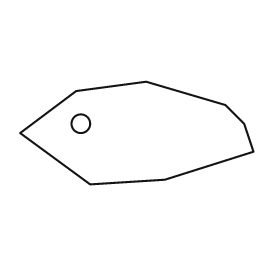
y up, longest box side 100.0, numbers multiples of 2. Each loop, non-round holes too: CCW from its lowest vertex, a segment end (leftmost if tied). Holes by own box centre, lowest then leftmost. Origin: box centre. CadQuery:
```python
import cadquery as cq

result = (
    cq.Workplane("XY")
    .moveTo(-20.0, -22.0)
    .lineTo(12.0, -20.0)
    .lineTo(50.0, -8.0)
    .lineTo(46.0, 4.0)
    .lineTo(38.0, 12.0)
    .lineTo(4.0, 22.0)
    .lineTo(-26.0, 18.0)
    .lineTo(-50.0, 0.0)
    .close()
    .moveTo(-24.0, 4.0)
    .circle(4.0)
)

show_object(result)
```